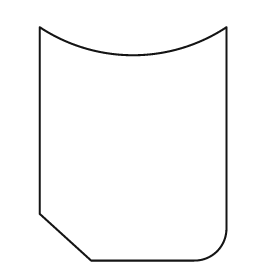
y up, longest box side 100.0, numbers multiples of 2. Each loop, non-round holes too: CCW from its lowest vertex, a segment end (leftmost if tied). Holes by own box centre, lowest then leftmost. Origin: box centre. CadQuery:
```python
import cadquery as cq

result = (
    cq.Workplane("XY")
    .moveTo(-18.0, -50.0)
    .lineTo(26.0, -50.0)
    .threePointArc((36.0, -46.0), (40.0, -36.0))
    .lineTo(40.0, 50.0)
    .threePointArc((0.0, 38.0), (-40.0, 50.0))
    .lineTo(-40.0, -30.0)
    .close()
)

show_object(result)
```